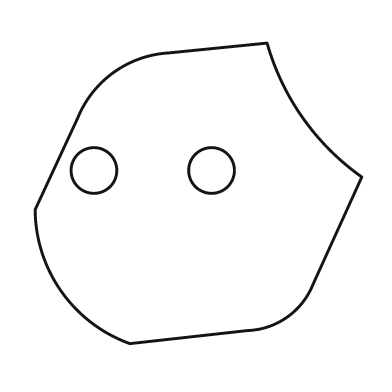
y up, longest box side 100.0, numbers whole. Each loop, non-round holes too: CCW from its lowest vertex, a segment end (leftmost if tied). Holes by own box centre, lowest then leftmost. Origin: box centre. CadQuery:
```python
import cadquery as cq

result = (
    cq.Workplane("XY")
    .moveTo(-21.0, -46.0)
    .lineTo(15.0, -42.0)
    .threePointArc((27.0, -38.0), (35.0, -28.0))
    .lineTo(50.0, 5.0)
    .threePointArc((32.0, 23.0), (21.0, 46.0))
    .lineTo(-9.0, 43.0)
    .threePointArc((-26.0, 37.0), (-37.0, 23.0))
    .lineTo(-50.0, -5.0)
    .threePointArc((-42.0, -30.0), (-21.0, -46.0))
    .close()
    .moveTo(-32.0, 7.0)
    .circle(7.0)
    .moveTo(4.0, 7.0)
    .circle(7.0)
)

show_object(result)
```